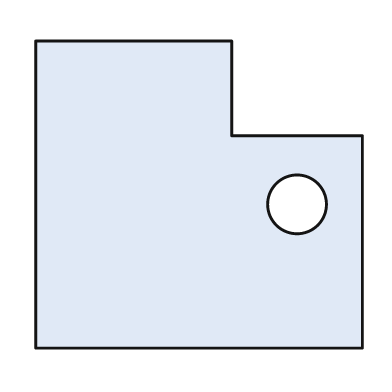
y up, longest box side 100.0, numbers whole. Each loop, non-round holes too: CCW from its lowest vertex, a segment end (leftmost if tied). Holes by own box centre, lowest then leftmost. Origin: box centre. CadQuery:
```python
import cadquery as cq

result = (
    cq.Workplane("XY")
    .moveTo(-50.0, -47.0)
    .lineTo(50.0, -47.0)
    .lineTo(50.0, 18.0)
    .lineTo(10.0, 18.0)
    .lineTo(10.0, 47.0)
    .lineTo(-50.0, 47.0)
    .close()
    .moveTo(30.0, -3.0)
    .circle(9.0)
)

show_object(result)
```